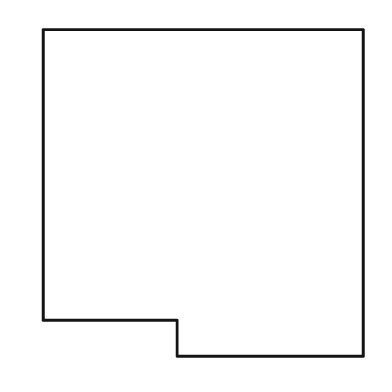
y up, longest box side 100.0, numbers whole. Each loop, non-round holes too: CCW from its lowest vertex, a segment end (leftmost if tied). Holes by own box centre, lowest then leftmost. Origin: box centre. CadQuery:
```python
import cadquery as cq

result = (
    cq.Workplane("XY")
    .moveTo(-8.0, -50.0)
    .lineTo(49.0, -50.0)
    .lineTo(49.0, 50.0)
    .lineTo(-49.0, 50.0)
    .lineTo(-49.0, -39.0)
    .lineTo(-8.0, -39.0)
    .close()
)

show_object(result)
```